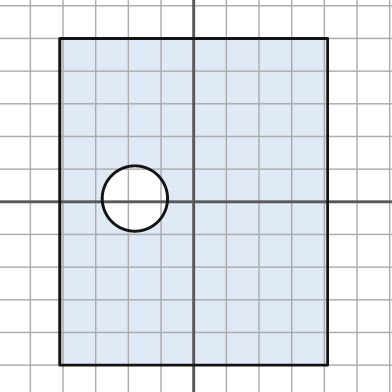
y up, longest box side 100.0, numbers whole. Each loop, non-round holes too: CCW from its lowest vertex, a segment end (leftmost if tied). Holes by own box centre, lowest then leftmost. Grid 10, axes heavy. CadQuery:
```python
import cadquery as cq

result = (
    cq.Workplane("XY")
    .moveTo(-41.0, -50.0)
    .lineTo(41.0, -50.0)
    .lineTo(41.0, 50.0)
    .lineTo(-41.0, 50.0)
    .close()
    .moveTo(-18.0, 1.0)
    .circle(10.0)
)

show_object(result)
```